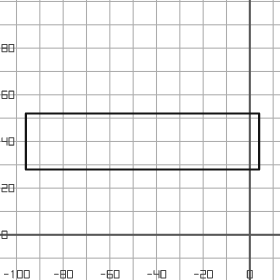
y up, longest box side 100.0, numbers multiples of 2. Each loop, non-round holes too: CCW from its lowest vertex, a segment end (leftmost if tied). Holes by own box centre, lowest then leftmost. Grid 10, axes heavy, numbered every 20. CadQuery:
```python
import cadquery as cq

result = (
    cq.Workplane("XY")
    .moveTo(-96.0, 28.0)
    .lineTo(4.0, 28.0)
    .lineTo(4.0, 52.0)
    .lineTo(-96.0, 52.0)
    .close()
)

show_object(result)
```